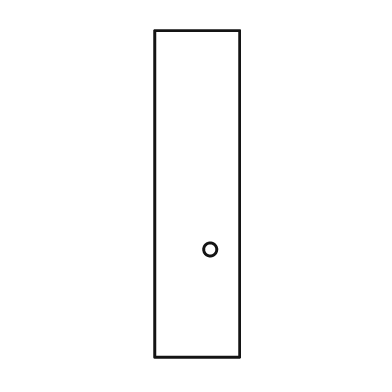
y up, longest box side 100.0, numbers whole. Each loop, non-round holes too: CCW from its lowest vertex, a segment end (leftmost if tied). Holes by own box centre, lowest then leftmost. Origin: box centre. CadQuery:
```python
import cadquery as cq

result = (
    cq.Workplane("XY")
    .moveTo(-13.0, -50.0)
    .lineTo(13.0, -50.0)
    .lineTo(13.0, 50.0)
    .lineTo(-13.0, 50.0)
    .close()
    .moveTo(4.0, -17.0)
    .circle(2.0)
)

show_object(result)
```